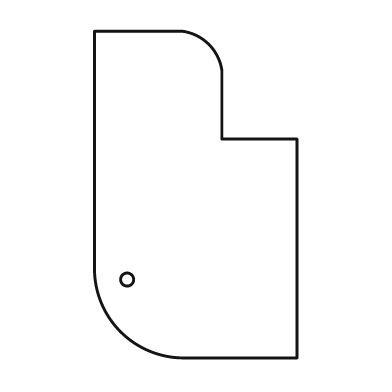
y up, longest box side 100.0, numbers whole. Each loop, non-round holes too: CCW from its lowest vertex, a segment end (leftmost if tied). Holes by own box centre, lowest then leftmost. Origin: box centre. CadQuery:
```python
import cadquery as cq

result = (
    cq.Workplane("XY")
    .moveTo(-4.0, -50.0)
    .lineTo(31.0, -50.0)
    .lineTo(31.0, 17.0)
    .lineTo(8.0, 17.0)
    .lineTo(8.0, 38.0)
    .threePointArc((4.0, 46.0), (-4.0, 50.0))
    .lineTo(-31.0, 50.0)
    .lineTo(-31.0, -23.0)
    .threePointArc((-23.0, -42.0), (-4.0, -50.0))
    .close()
    .moveTo(-21.0, -26.0)
    .circle(2.0)
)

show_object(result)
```